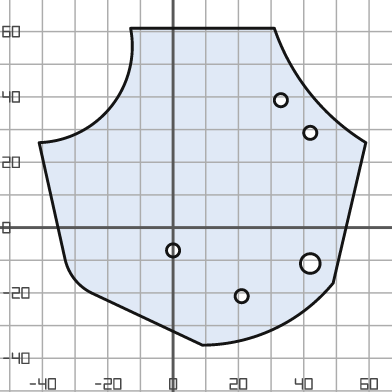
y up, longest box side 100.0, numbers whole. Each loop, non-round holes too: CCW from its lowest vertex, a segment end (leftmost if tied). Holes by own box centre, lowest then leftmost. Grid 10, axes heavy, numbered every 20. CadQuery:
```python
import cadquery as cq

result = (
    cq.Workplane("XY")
    .moveTo(9.0, -36.0)
    .threePointArc((31.0, -31.0), (49.0, -17.0))
    .lineTo(59.0, 26.0)
    .threePointArc((42.0, 41.0), (31.0, 61.0))
    .lineTo(-13.0, 61.0)
    .threePointArc((-19.0, 37.0), (-41.0, 26.0))
    .lineTo(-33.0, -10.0)
    .threePointArc((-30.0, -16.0), (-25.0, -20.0))
    .close()
    .moveTo(21.0, -21.0)
    .circle(2.0)
    .moveTo(42.0, -11.0)
    .circle(3.0)
    .moveTo(0.0, -7.0)
    .circle(2.0)
    .moveTo(42.0, 29.0)
    .circle(2.0)
    .moveTo(33.0, 39.0)
    .circle(2.0)
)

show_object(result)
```